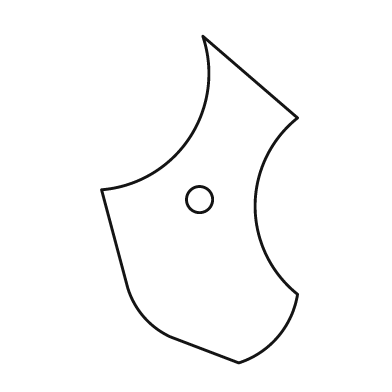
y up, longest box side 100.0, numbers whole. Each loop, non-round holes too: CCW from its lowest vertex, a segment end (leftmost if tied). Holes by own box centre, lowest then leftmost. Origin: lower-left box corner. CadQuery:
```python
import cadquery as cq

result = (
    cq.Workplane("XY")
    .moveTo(42.0, 0.0)
    .threePointArc((54.0, 8.0), (60.0, 21.0))
    .threePointArc((47.0, 48.0), (60.0, 75.0))
    .lineTo(31.0, 100.0)
    .threePointArc((27.0, 69.0), (0.0, 53.0))
    .lineTo(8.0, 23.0)
    .threePointArc((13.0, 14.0), (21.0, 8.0))
    .close()
    .moveTo(30.0, 50.0)
    .circle(4.0)
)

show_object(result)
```